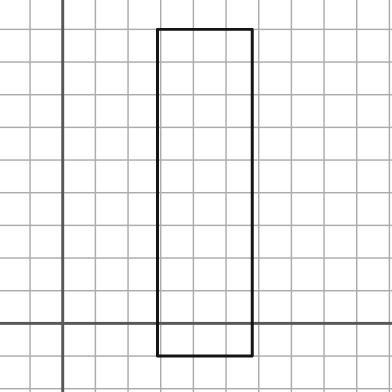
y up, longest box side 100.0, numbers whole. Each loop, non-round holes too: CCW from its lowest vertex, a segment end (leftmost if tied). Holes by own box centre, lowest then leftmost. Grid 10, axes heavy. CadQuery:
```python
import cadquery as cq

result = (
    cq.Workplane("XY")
    .moveTo(29.0, -10.0)
    .lineTo(58.0, -10.0)
    .lineTo(58.0, 90.0)
    .lineTo(29.0, 90.0)
    .close()
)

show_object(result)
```